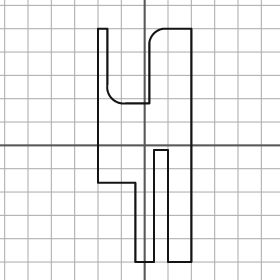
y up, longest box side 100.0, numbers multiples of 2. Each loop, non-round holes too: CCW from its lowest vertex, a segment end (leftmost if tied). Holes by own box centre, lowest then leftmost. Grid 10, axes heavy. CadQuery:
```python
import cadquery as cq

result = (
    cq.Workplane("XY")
    .moveTo(-4.0, -50.0)
    .lineTo(4.0, -50.0)
    .lineTo(4.0, -2.0)
    .lineTo(10.0, -2.0)
    .lineTo(10.0, -50.0)
    .lineTo(20.0, -50.0)
    .lineTo(20.0, 50.0)
    .lineTo(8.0, 50.0)
    .threePointArc((4.0, 48.0), (2.0, 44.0))
    .lineTo(2.0, 18.0)
    .lineTo(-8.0, 18.0)
    .threePointArc((-14.0, 20.0), (-16.0, 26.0))
    .lineTo(-16.0, 50.0)
    .lineTo(-20.0, 50.0)
    .lineTo(-20.0, -16.0)
    .lineTo(-4.0, -16.0)
    .close()
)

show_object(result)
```